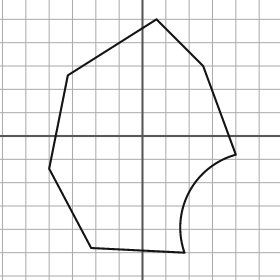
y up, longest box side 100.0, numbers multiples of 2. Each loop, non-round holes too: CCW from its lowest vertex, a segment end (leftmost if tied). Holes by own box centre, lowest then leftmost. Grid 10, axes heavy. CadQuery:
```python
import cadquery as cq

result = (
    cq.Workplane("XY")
    .moveTo(18.0, -50.0)
    .threePointArc((20.0, -24.0), (40.0, -8.0))
    .lineTo(26.0, 30.0)
    .lineTo(6.0, 50.0)
    .lineTo(-32.0, 26.0)
    .lineTo(-40.0, -14.0)
    .lineTo(-22.0, -48.0)
    .close()
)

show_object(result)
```